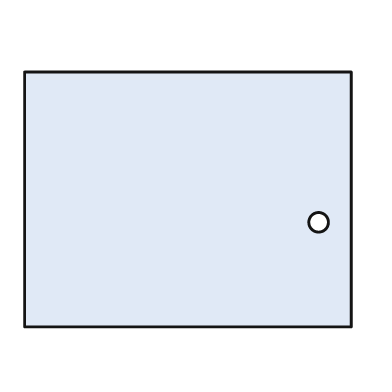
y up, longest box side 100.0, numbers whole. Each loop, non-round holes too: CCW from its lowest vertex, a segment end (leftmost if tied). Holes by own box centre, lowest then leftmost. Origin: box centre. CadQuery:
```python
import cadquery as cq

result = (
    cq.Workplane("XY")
    .moveTo(-50.0, -39.0)
    .lineTo(50.0, -39.0)
    .lineTo(50.0, 39.0)
    .lineTo(-50.0, 39.0)
    .close()
    .moveTo(40.0, -7.0)
    .circle(3.0)
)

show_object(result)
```